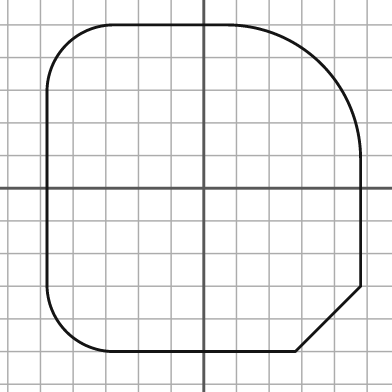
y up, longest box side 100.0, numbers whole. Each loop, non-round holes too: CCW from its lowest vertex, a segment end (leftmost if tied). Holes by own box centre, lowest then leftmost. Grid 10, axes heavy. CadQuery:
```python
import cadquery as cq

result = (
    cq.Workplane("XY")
    .moveTo(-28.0, -50.0)
    .lineTo(28.0, -50.0)
    .lineTo(48.0, -30.0)
    .lineTo(48.0, 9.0)
    .threePointArc((36.0, 38.0), (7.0, 50.0))
    .lineTo(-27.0, 50.0)
    .threePointArc((-42.0, 44.0), (-48.0, 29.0))
    .lineTo(-48.0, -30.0)
    .threePointArc((-42.0, -44.0), (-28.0, -50.0))
    .close()
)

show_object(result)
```